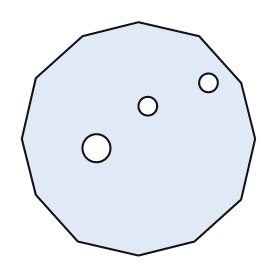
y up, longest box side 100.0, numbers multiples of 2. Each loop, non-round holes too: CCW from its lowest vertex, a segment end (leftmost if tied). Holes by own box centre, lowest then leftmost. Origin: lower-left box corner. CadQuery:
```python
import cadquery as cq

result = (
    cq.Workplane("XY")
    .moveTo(50.0, 0.0)
    .lineTo(74.0, 6.0)
    .lineTo(94.0, 24.0)
    .lineTo(100.0, 50.0)
    .lineTo(94.0, 74.0)
    .lineTo(76.0, 94.0)
    .lineTo(50.0, 100.0)
    .lineTo(26.0, 94.0)
    .lineTo(6.0, 76.0)
    .lineTo(0.0, 50.0)
    .lineTo(6.0, 26.0)
    .lineTo(24.0, 6.0)
    .close()
    .moveTo(32.0, 46.0)
    .circle(6.0)
    .moveTo(54.0, 64.0)
    .circle(4.0)
    .moveTo(80.0, 74.0)
    .circle(4.0)
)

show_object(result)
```